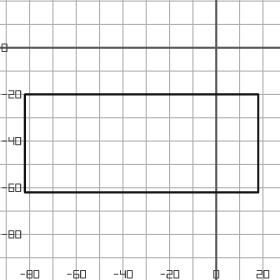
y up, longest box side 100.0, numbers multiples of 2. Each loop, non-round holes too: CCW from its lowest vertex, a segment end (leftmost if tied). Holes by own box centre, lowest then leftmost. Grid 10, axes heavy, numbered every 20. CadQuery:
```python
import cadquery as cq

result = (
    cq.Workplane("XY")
    .moveTo(-82.0, -62.0)
    .lineTo(18.0, -62.0)
    .lineTo(18.0, -20.0)
    .lineTo(-82.0, -20.0)
    .close()
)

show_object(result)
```